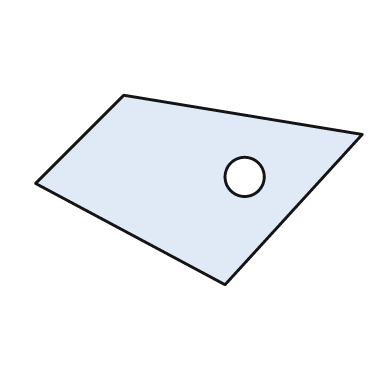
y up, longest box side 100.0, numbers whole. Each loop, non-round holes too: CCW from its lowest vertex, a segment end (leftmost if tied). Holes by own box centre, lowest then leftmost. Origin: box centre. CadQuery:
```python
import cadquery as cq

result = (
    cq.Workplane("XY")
    .moveTo(8.0, -29.0)
    .lineTo(50.0, 17.0)
    .lineTo(-23.0, 29.0)
    .lineTo(-50.0, 2.0)
    .close()
    .moveTo(14.0, 4.0)
    .circle(6.0)
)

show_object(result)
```